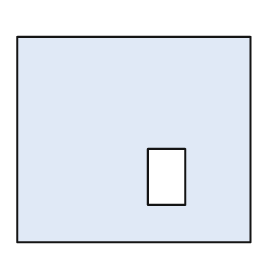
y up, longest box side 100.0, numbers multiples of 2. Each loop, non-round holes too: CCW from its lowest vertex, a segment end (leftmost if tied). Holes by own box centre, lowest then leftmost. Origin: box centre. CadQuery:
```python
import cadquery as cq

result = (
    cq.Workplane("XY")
    .moveTo(-50.0, -44.0)
    .lineTo(50.0, -44.0)
    .lineTo(50.0, 44.0)
    .lineTo(-50.0, 44.0)
    .close()
    .moveTo(6.0, -28.0)
    .lineTo(22.0, -28.0)
    .lineTo(22.0, -4.0)
    .lineTo(6.0, -4.0)
    .close()
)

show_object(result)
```